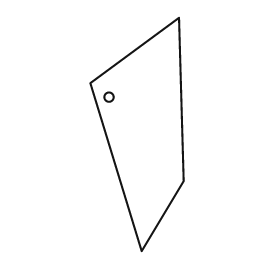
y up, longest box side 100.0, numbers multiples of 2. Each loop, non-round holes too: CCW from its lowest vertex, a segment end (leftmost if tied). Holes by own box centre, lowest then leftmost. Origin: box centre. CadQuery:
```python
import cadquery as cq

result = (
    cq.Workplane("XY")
    .moveTo(2.0, -50.0)
    .lineTo(20.0, -20.0)
    .lineTo(18.0, 50.0)
    .lineTo(-20.0, 22.0)
    .close()
    .moveTo(-12.0, 16.0)
    .circle(2.0)
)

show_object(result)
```